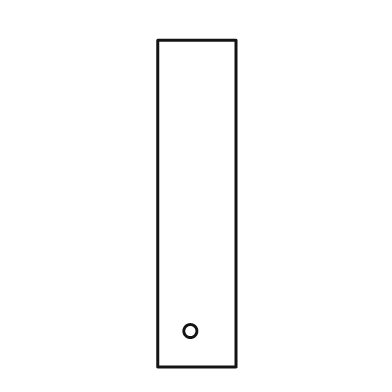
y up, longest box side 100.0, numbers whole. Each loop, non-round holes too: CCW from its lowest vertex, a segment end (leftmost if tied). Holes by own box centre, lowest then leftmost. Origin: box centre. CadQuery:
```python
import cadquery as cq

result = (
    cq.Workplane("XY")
    .moveTo(-12.0, -50.0)
    .lineTo(12.0, -50.0)
    .lineTo(12.0, 50.0)
    .lineTo(-12.0, 50.0)
    .close()
    .moveTo(-2.0, -39.0)
    .circle(2.0)
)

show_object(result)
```